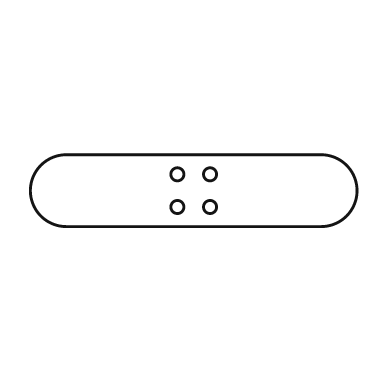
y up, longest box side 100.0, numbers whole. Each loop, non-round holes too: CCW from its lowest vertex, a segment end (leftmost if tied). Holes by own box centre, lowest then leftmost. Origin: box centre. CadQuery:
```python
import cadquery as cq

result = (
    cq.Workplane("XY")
    .moveTo(-39.0, -11.0)
    .lineTo(39.0, -11.0)
    .threePointArc((50.0, 0.0), (39.0, 11.0))
    .lineTo(-39.0, 11.0)
    .threePointArc((-50.0, 0.0), (-39.0, -11.0))
    .close()
    .moveTo(-5.0, -5.0)
    .circle(2.0)
    .moveTo(5.0, -5.0)
    .circle(2.0)
    .moveTo(-5.0, 5.0)
    .circle(2.0)
    .moveTo(5.0, 5.0)
    .circle(2.0)
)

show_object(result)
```